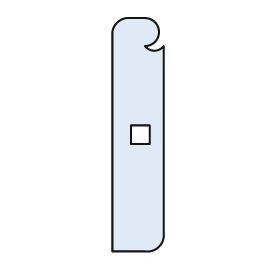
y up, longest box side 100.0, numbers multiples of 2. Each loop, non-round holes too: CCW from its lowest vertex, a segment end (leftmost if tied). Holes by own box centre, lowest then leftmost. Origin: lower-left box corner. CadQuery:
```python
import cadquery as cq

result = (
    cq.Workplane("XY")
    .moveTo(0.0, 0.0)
    .lineTo(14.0, 0.0)
    .threePointArc((20.0, 2.0), (22.0, 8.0))
    .lineTo(22.0, 88.0)
    .threePointArc((18.0, 86.0), (14.0, 88.0))
    .threePointArc((20.0, 94.0), (14.0, 100.0))
    .lineTo(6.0, 100.0)
    .threePointArc((2.0, 98.0), (0.0, 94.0))
    .close()
    .moveTo(8.0, 46.0)
    .lineTo(16.0, 46.0)
    .lineTo(16.0, 54.0)
    .lineTo(8.0, 54.0)
    .close()
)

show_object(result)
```